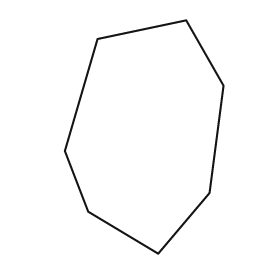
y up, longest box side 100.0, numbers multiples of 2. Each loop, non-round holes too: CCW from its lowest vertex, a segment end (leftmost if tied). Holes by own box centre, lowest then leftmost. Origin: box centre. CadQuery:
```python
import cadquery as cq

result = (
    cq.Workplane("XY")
    .moveTo(6.0, -50.0)
    .lineTo(28.0, -24.0)
    .lineTo(34.0, 22.0)
    .lineTo(18.0, 50.0)
    .lineTo(-20.0, 42.0)
    .lineTo(-34.0, -6.0)
    .lineTo(-24.0, -32.0)
    .close()
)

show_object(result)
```